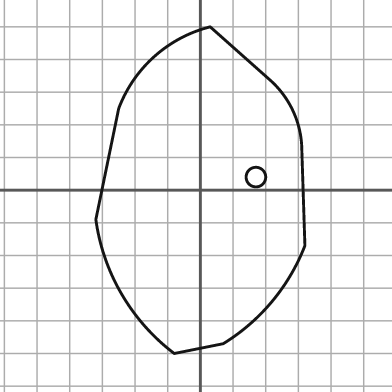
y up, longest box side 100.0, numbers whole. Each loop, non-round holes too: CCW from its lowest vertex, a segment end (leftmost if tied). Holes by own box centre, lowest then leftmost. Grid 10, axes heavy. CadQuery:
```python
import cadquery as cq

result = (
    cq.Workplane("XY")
    .moveTo(-8.0, -50.0)
    .lineTo(7.0, -47.0)
    .threePointArc((22.0, -34.0), (32.0, -17.0))
    .lineTo(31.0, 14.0)
    .threePointArc((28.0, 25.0), (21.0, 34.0))
    .lineTo(3.0, 50.0)
    .threePointArc((-14.0, 41.0), (-25.0, 25.0))
    .lineTo(-32.0, -9.0)
    .threePointArc((-24.0, -32.0), (-8.0, -50.0))
    .close()
    .moveTo(17.0, 4.0)
    .circle(3.0)
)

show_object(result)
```